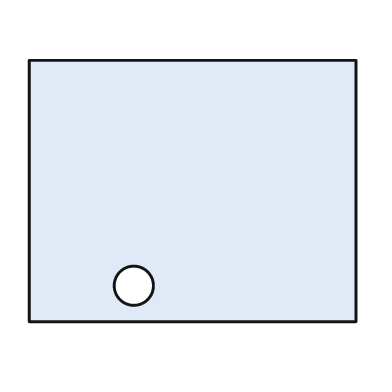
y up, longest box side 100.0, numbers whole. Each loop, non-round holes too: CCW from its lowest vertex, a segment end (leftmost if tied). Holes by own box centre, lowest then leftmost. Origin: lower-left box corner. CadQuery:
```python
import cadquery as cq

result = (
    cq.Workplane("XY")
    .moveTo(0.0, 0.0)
    .lineTo(100.0, 0.0)
    .lineTo(100.0, 80.0)
    .lineTo(0.0, 80.0)
    .close()
    .moveTo(32.0, 11.0)
    .circle(6.0)
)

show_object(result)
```